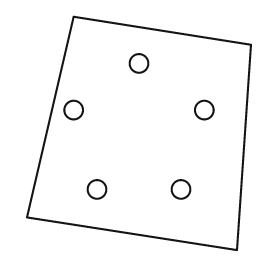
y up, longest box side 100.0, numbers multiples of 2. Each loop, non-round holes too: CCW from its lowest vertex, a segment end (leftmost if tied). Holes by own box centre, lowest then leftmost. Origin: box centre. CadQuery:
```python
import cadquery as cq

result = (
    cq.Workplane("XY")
    .moveTo(42.0, -50.0)
    .lineTo(48.0, 38.0)
    .lineTo(-28.0, 50.0)
    .lineTo(-48.0, -36.0)
    .close()
    .moveTo(-18.0, -24.0)
    .circle(4.0)
    .moveTo(18.0, -24.0)
    .circle(4.0)
    .moveTo(-28.0, 10.0)
    .circle(4.0)
    .moveTo(28.0, 10.0)
    .circle(4.0)
    .moveTo(0.0, 30.0)
    .circle(4.0)
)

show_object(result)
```